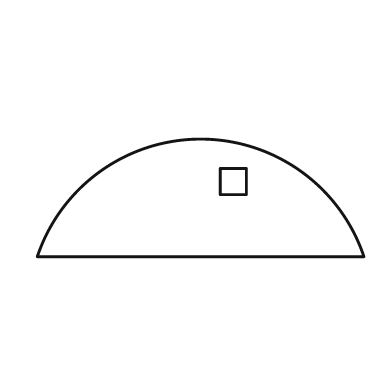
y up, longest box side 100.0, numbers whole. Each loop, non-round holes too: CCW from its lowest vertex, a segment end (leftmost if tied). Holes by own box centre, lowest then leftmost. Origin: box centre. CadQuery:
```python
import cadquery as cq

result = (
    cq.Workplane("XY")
    .moveTo(-50.0, -18.0)
    .lineTo(50.0, -18.0)
    .threePointArc((0.0, 18.0), (-50.0, -18.0))
    .close()
    .moveTo(6.0, 1.0)
    .lineTo(14.0, 1.0)
    .lineTo(14.0, 9.0)
    .lineTo(6.0, 9.0)
    .close()
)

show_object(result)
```